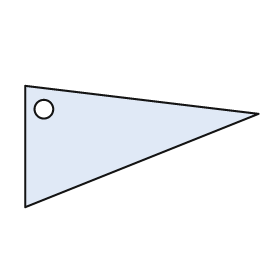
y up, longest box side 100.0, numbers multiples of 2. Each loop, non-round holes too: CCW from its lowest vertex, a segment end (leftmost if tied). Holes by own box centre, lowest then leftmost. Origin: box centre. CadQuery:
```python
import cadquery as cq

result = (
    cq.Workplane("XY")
    .moveTo(-50.0, -26.0)
    .lineTo(50.0, 14.0)
    .lineTo(-50.0, 26.0)
    .close()
    .moveTo(-42.0, 16.0)
    .circle(4.0)
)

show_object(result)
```